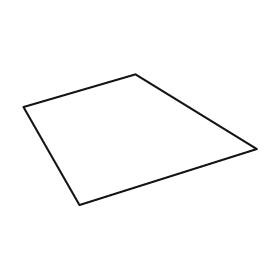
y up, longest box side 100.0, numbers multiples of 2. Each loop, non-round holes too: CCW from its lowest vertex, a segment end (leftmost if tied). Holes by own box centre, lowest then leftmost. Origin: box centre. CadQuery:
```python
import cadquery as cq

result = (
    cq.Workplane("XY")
    .moveTo(-26.0, -28.0)
    .lineTo(50.0, -4.0)
    .lineTo(-2.0, 28.0)
    .lineTo(-50.0, 14.0)
    .close()
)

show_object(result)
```